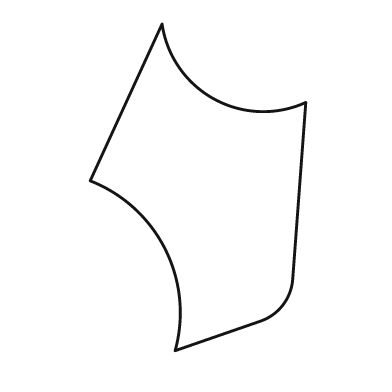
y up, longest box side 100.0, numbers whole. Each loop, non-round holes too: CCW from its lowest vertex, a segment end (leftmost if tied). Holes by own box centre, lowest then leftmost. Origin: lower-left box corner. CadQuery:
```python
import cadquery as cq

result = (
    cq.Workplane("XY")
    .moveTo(26.0, 0.0)
    .lineTo(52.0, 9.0)
    .threePointArc((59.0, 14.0), (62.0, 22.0))
    .lineTo(66.0, 76.0)
    .threePointArc((38.0, 77.0), (22.0, 100.0))
    .lineTo(0.0, 52.0)
    .threePointArc((23.0, 31.0), (26.0, 0.0))
    .close()
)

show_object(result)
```